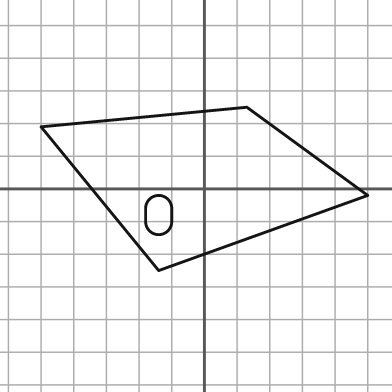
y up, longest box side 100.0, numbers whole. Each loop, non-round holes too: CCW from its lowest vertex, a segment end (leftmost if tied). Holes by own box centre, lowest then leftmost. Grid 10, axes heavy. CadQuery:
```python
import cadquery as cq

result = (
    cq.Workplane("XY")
    .moveTo(-14.0, -25.0)
    .lineTo(50.0, -2.0)
    .lineTo(13.0, 25.0)
    .lineTo(-50.0, 19.0)
    .close()
    .moveTo(-18.0, -10.0)
    .threePointArc((-14.0, -14.0), (-10.0, -10.0))
    .lineTo(-10.0, -6.0)
    .threePointArc((-14.0, -2.0), (-18.0, -6.0))
    .close()
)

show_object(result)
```